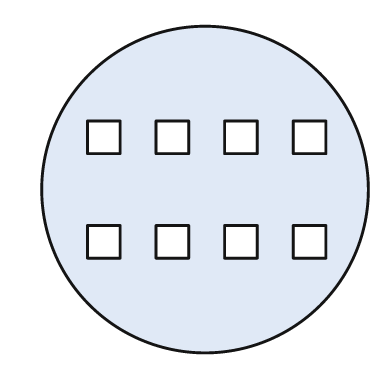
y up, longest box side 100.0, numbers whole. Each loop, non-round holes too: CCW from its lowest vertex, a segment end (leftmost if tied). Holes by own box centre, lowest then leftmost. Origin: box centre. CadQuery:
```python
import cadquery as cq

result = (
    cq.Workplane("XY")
    .moveTo(0.0, 0.0)
    .circle(50.0)
    .moveTo(-36.0, -21.0)
    .lineTo(-26.0, -21.0)
    .lineTo(-26.0, -11.0)
    .lineTo(-36.0, -11.0)
    .close()
    .moveTo(-15.0, -21.0)
    .lineTo(-5.0, -21.0)
    .lineTo(-5.0, -11.0)
    .lineTo(-15.0, -11.0)
    .close()
    .moveTo(6.0, -21.0)
    .lineTo(16.0, -21.0)
    .lineTo(16.0, -11.0)
    .lineTo(6.0, -11.0)
    .close()
    .moveTo(27.0, -21.0)
    .lineTo(37.0, -21.0)
    .lineTo(37.0, -11.0)
    .lineTo(27.0, -11.0)
    .close()
    .moveTo(-36.0, 11.0)
    .lineTo(-26.0, 11.0)
    .lineTo(-26.0, 21.0)
    .lineTo(-36.0, 21.0)
    .close()
    .moveTo(-15.0, 11.0)
    .lineTo(-5.0, 11.0)
    .lineTo(-5.0, 21.0)
    .lineTo(-15.0, 21.0)
    .close()
    .moveTo(6.0, 11.0)
    .lineTo(16.0, 11.0)
    .lineTo(16.0, 21.0)
    .lineTo(6.0, 21.0)
    .close()
    .moveTo(27.0, 11.0)
    .lineTo(37.0, 11.0)
    .lineTo(37.0, 21.0)
    .lineTo(27.0, 21.0)
    .close()
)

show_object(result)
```